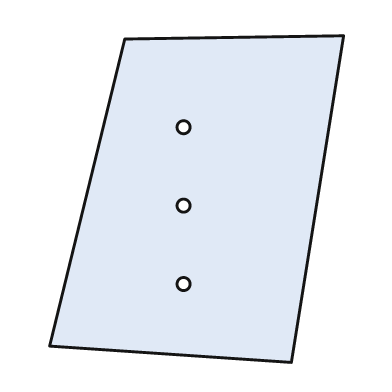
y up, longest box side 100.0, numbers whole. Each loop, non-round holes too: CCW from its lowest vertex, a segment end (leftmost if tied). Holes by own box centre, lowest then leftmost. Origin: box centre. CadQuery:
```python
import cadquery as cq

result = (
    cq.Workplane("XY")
    .moveTo(29.0, -50.0)
    .lineTo(45.0, 50.0)
    .lineTo(-22.0, 49.0)
    .lineTo(-45.0, -45.0)
    .close()
    .moveTo(-4.0, -26.0)
    .circle(2.0)
    .moveTo(-4.0, -2.0)
    .circle(2.0)
    .moveTo(-4.0, 22.0)
    .circle(2.0)
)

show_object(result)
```